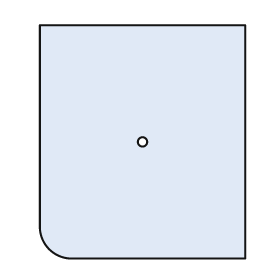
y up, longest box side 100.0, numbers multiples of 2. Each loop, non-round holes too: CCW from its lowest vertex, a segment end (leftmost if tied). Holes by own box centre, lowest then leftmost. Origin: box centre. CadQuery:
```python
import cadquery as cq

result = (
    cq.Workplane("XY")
    .moveTo(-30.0, -50.0)
    .lineTo(44.0, -50.0)
    .lineTo(44.0, 50.0)
    .lineTo(-44.0, 50.0)
    .lineTo(-44.0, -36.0)
    .threePointArc((-40.0, -46.0), (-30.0, -50.0))
    .close()
    .moveTo(0.0, 0.0)
    .circle(2.0)
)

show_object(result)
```